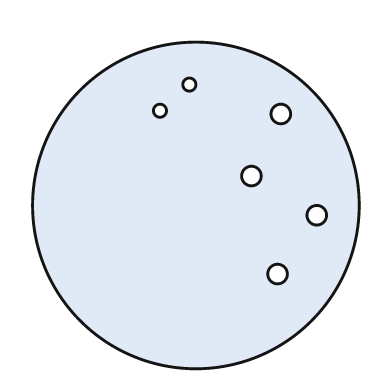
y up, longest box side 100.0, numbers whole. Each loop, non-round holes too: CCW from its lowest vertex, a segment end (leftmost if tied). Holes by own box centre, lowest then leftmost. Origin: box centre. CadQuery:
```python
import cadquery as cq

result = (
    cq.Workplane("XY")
    .moveTo(0.0, 0.0)
    .circle(50.0)
    .moveTo(25.0, -21.0)
    .circle(3.0)
    .moveTo(37.0, -3.0)
    .circle(3.0)
    .moveTo(17.0, 9.0)
    .circle(3.0)
    .moveTo(26.0, 28.0)
    .circle(3.0)
    .moveTo(-11.0, 29.0)
    .circle(2.0)
    .moveTo(-2.0, 37.0)
    .circle(2.0)
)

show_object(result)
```